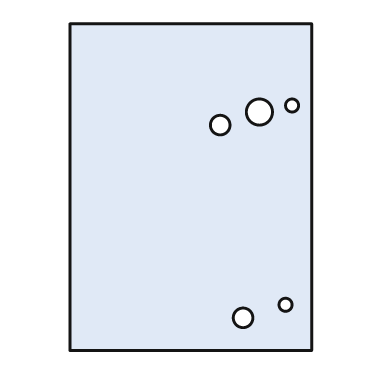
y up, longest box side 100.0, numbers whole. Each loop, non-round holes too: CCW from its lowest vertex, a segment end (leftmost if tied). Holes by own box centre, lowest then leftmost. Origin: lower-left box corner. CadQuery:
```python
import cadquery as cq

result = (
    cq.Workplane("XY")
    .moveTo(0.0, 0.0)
    .lineTo(74.0, 0.0)
    .lineTo(74.0, 100.0)
    .lineTo(0.0, 100.0)
    .close()
    .moveTo(53.0, 10.0)
    .circle(3.0)
    .moveTo(66.0, 14.0)
    .circle(2.0)
    .moveTo(46.0, 69.0)
    .circle(3.0)
    .moveTo(58.0, 73.0)
    .circle(4.0)
    .moveTo(68.0, 75.0)
    .circle(2.0)
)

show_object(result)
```